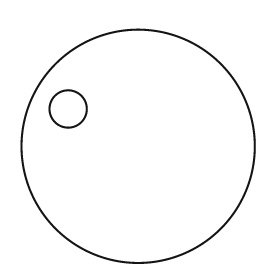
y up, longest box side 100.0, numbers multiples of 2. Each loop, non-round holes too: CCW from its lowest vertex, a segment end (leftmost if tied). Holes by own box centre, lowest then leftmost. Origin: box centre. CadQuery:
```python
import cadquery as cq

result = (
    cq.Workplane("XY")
    .moveTo(0.0, 0.0)
    .circle(50.0)
    .moveTo(-30.0, 16.0)
    .circle(8.0)
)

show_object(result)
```